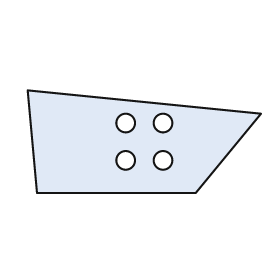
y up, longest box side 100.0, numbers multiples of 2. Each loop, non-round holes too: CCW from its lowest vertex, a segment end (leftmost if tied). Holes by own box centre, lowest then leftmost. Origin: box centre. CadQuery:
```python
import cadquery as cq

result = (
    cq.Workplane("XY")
    .moveTo(-46.0, -22.0)
    .lineTo(22.0, -22.0)
    .lineTo(50.0, 12.0)
    .lineTo(-50.0, 22.0)
    .close()
    .moveTo(-8.0, -8.0)
    .circle(4.0)
    .moveTo(8.0, -8.0)
    .circle(4.0)
    .moveTo(-8.0, 8.0)
    .circle(4.0)
    .moveTo(8.0, 8.0)
    .circle(4.0)
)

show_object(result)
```